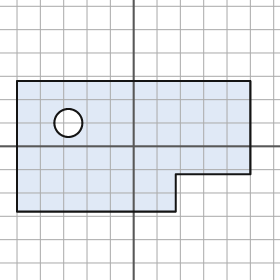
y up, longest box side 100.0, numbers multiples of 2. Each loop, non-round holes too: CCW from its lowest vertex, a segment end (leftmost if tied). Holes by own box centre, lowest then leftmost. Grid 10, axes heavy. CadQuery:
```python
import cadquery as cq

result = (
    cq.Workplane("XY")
    .moveTo(-50.0, -28.0)
    .lineTo(18.0, -28.0)
    .lineTo(18.0, -12.0)
    .lineTo(50.0, -12.0)
    .lineTo(50.0, 28.0)
    .lineTo(-50.0, 28.0)
    .close()
    .moveTo(-28.0, 10.0)
    .circle(6.0)
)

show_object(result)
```